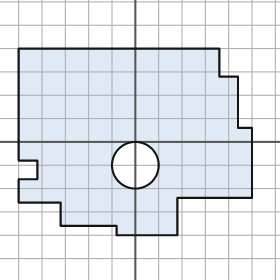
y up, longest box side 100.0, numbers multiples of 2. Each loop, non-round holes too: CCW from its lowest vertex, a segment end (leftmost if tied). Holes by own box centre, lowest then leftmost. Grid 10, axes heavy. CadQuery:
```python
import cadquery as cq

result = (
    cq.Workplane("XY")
    .moveTo(-8.0, -40.0)
    .lineTo(18.0, -40.0)
    .lineTo(18.0, -24.0)
    .lineTo(50.0, -24.0)
    .lineTo(50.0, 6.0)
    .lineTo(44.0, 6.0)
    .lineTo(44.0, 28.0)
    .lineTo(36.0, 28.0)
    .lineTo(36.0, 40.0)
    .lineTo(-50.0, 40.0)
    .lineTo(-50.0, -8.0)
    .lineTo(-42.0, -8.0)
    .lineTo(-42.0, -16.0)
    .lineTo(-50.0, -16.0)
    .lineTo(-50.0, -26.0)
    .lineTo(-32.0, -26.0)
    .lineTo(-32.0, -36.0)
    .lineTo(-8.0, -36.0)
    .close()
    .moveTo(0.0, -10.0)
    .circle(10.0)
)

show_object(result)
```